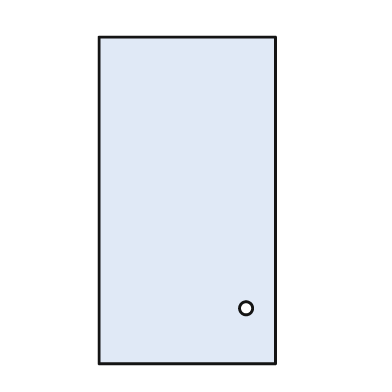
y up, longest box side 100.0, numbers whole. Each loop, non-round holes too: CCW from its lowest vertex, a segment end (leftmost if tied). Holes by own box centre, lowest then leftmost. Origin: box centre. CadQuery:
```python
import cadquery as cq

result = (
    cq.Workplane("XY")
    .moveTo(-27.0, -50.0)
    .lineTo(27.0, -50.0)
    .lineTo(27.0, 50.0)
    .lineTo(-27.0, 50.0)
    .close()
    .moveTo(18.0, -33.0)
    .circle(2.0)
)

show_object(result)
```